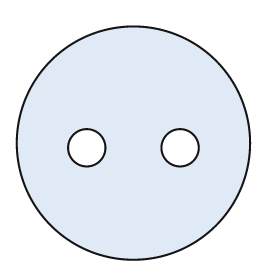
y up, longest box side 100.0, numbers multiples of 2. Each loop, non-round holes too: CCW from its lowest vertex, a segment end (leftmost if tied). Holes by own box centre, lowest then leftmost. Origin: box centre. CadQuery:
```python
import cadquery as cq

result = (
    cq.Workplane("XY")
    .moveTo(0.0, 0.0)
    .circle(50.0)
    .moveTo(-20.0, -2.0)
    .circle(8.0)
    .moveTo(20.0, -2.0)
    .circle(8.0)
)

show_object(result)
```